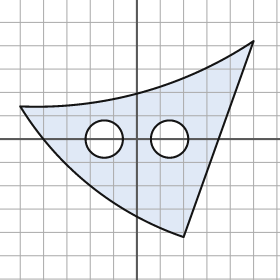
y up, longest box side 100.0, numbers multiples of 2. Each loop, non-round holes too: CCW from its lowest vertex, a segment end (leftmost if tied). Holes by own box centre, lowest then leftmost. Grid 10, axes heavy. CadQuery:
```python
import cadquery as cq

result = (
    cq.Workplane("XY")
    .moveTo(20.0, -42.0)
    .lineTo(50.0, 42.0)
    .threePointArc((2.0, 20.0), (-50.0, 14.0))
    .threePointArc((-20.0, -20.0), (20.0, -42.0))
    .close()
    .moveTo(-14.0, 0.0)
    .circle(8.0)
    .moveTo(14.0, 0.0)
    .circle(8.0)
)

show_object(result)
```